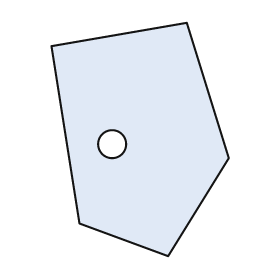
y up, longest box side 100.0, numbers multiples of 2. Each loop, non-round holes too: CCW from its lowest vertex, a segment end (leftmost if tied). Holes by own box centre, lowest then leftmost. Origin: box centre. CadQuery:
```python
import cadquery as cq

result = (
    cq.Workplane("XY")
    .moveTo(12.0, -50.0)
    .lineTo(38.0, -8.0)
    .lineTo(20.0, 50.0)
    .lineTo(-38.0, 40.0)
    .lineTo(-26.0, -36.0)
    .close()
    .moveTo(-12.0, -2.0)
    .circle(6.0)
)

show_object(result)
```